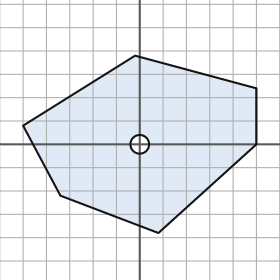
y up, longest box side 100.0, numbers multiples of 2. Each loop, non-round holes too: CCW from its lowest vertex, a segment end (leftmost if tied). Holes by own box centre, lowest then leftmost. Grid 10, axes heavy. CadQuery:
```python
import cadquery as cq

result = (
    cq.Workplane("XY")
    .moveTo(8.0, -38.0)
    .lineTo(50.0, 0.0)
    .lineTo(50.0, 24.0)
    .lineTo(-2.0, 38.0)
    .lineTo(-50.0, 8.0)
    .lineTo(-34.0, -22.0)
    .close()
    .moveTo(0.0, 0.0)
    .circle(4.0)
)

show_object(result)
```